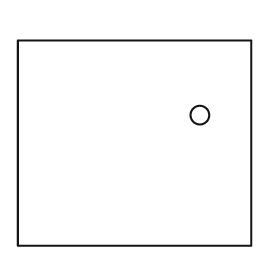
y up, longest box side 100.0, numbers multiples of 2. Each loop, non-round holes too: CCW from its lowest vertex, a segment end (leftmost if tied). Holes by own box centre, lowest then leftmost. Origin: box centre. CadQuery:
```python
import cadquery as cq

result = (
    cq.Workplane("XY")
    .moveTo(-50.0, -44.0)
    .lineTo(50.0, -44.0)
    .lineTo(50.0, 44.0)
    .lineTo(-50.0, 44.0)
    .close()
    .moveTo(28.0, 12.0)
    .circle(4.0)
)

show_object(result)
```